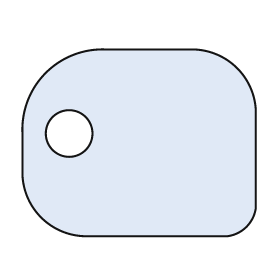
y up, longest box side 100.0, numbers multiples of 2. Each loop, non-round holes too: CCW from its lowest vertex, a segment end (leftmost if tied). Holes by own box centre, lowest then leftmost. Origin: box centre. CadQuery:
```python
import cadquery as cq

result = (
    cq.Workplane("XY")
    .moveTo(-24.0, -40.0)
    .lineTo(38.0, -40.0)
    .threePointArc((46.0, -36.0), (50.0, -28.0))
    .lineTo(50.0, 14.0)
    .threePointArc((42.0, 32.0), (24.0, 40.0))
    .lineTo(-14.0, 40.0)
    .threePointArc((-40.0, 30.0), (-50.0, 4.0))
    .lineTo(-50.0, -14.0)
    .threePointArc((-42.0, -32.0), (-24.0, -40.0))
    .close()
    .moveTo(-30.0, 4.0)
    .circle(10.0)
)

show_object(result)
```